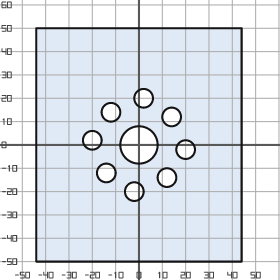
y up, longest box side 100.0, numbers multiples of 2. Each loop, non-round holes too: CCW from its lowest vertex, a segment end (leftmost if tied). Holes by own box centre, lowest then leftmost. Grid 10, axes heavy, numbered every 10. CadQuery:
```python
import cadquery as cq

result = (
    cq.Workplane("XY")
    .moveTo(-44.0, -50.0)
    .lineTo(44.0, -50.0)
    .lineTo(44.0, 50.0)
    .lineTo(-44.0, 50.0)
    .close()
    .moveTo(-2.0, -20.0)
    .circle(4.0)
    .moveTo(12.0, -14.0)
    .circle(4.0)
    .moveTo(-14.0, -12.0)
    .circle(4.0)
    .moveTo(20.0, -2.0)
    .circle(4.0)
    .moveTo(0.0, 0.0)
    .circle(8.0)
    .moveTo(-20.0, 2.0)
    .circle(4.0)
    .moveTo(14.0, 12.0)
    .circle(4.0)
    .moveTo(-12.0, 14.0)
    .circle(4.0)
    .moveTo(2.0, 20.0)
    .circle(4.0)
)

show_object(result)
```